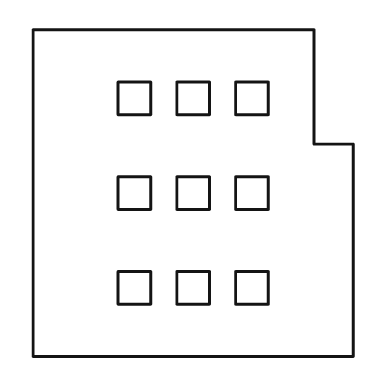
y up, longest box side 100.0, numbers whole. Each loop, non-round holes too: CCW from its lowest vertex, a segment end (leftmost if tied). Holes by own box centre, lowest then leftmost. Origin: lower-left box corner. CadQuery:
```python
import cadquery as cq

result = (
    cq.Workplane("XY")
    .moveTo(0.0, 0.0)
    .lineTo(98.0, 0.0)
    .lineTo(98.0, 65.0)
    .lineTo(86.0, 65.0)
    .lineTo(86.0, 100.0)
    .lineTo(0.0, 100.0)
    .close()
    .moveTo(26.0, 16.0)
    .lineTo(36.0, 16.0)
    .lineTo(36.0, 26.0)
    .lineTo(26.0, 26.0)
    .close()
    .moveTo(44.0, 16.0)
    .lineTo(54.0, 16.0)
    .lineTo(54.0, 26.0)
    .lineTo(44.0, 26.0)
    .close()
    .moveTo(62.0, 16.0)
    .lineTo(72.0, 16.0)
    .lineTo(72.0, 26.0)
    .lineTo(62.0, 26.0)
    .close()
    .moveTo(26.0, 45.0)
    .lineTo(36.0, 45.0)
    .lineTo(36.0, 55.0)
    .lineTo(26.0, 55.0)
    .close()
    .moveTo(44.0, 45.0)
    .lineTo(54.0, 45.0)
    .lineTo(54.0, 55.0)
    .lineTo(44.0, 55.0)
    .close()
    .moveTo(62.0, 45.0)
    .lineTo(72.0, 45.0)
    .lineTo(72.0, 55.0)
    .lineTo(62.0, 55.0)
    .close()
    .moveTo(26.0, 74.0)
    .lineTo(36.0, 74.0)
    .lineTo(36.0, 84.0)
    .lineTo(26.0, 84.0)
    .close()
    .moveTo(44.0, 74.0)
    .lineTo(54.0, 74.0)
    .lineTo(54.0, 84.0)
    .lineTo(44.0, 84.0)
    .close()
    .moveTo(62.0, 74.0)
    .lineTo(72.0, 74.0)
    .lineTo(72.0, 84.0)
    .lineTo(62.0, 84.0)
    .close()
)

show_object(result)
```